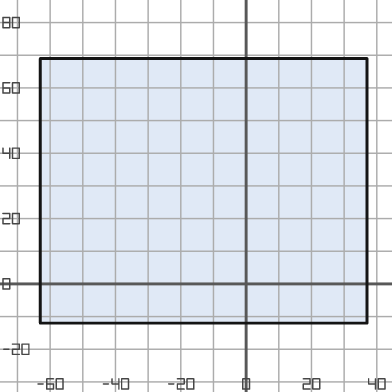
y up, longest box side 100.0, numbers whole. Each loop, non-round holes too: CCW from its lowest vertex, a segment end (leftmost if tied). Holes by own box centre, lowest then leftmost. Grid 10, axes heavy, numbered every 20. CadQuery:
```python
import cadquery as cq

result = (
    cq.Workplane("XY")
    .moveTo(-63.0, -12.0)
    .lineTo(37.0, -12.0)
    .lineTo(37.0, 69.0)
    .lineTo(-63.0, 69.0)
    .close()
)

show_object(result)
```